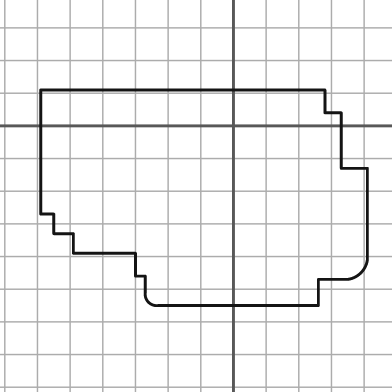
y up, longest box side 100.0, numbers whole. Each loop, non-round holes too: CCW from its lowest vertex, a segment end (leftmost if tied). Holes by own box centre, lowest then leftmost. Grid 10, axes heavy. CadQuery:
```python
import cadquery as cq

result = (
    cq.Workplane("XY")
    .moveTo(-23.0, -55.0)
    .lineTo(26.0, -55.0)
    .lineTo(26.0, -47.0)
    .lineTo(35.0, -47.0)
    .threePointArc((39.0, -45.0), (41.0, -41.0))
    .lineTo(41.0, -13.0)
    .lineTo(33.0, -13.0)
    .lineTo(33.0, 4.0)
    .lineTo(28.0, 4.0)
    .lineTo(28.0, 11.0)
    .lineTo(-59.0, 11.0)
    .lineTo(-59.0, -27.0)
    .lineTo(-55.0, -27.0)
    .lineTo(-55.0, -33.0)
    .lineTo(-49.0, -33.0)
    .lineTo(-49.0, -39.0)
    .lineTo(-30.0, -39.0)
    .lineTo(-30.0, -46.0)
    .lineTo(-27.0, -46.0)
    .lineTo(-27.0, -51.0)
    .threePointArc((-26.0, -54.0), (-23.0, -55.0))
    .close()
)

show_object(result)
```